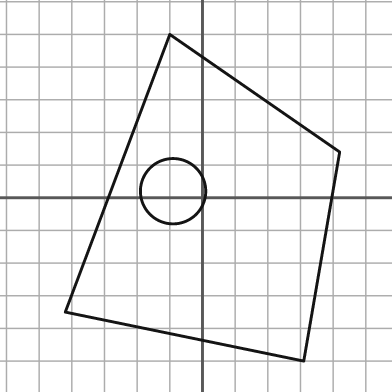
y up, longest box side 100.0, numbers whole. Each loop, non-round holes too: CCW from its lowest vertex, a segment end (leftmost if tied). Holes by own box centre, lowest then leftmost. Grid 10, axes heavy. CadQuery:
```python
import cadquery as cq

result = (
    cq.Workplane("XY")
    .moveTo(31.0, -50.0)
    .lineTo(42.0, 14.0)
    .lineTo(-10.0, 50.0)
    .lineTo(-42.0, -35.0)
    .close()
    .moveTo(-9.0, 2.0)
    .circle(10.0)
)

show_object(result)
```